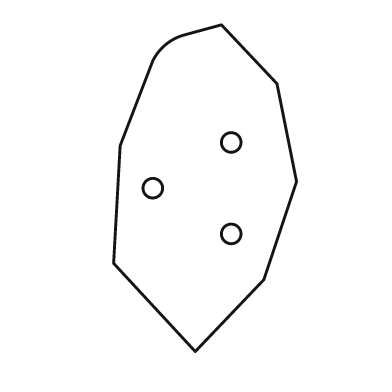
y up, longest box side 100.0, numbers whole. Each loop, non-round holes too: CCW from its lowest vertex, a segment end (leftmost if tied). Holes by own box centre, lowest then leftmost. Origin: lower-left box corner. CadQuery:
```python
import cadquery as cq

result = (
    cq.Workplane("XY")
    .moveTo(25.0, 0.0)
    .lineTo(46.0, 22.0)
    .lineTo(56.0, 52.0)
    .lineTo(50.0, 82.0)
    .lineTo(33.0, 100.0)
    .lineTo(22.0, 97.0)
    .threePointArc((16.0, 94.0), (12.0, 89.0))
    .lineTo(2.0, 63.0)
    .lineTo(0.0, 27.0)
    .close()
    .moveTo(36.0, 36.0)
    .circle(3.0)
    .moveTo(12.0, 50.0)
    .circle(3.0)
    .moveTo(36.0, 64.0)
    .circle(3.0)
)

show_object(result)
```